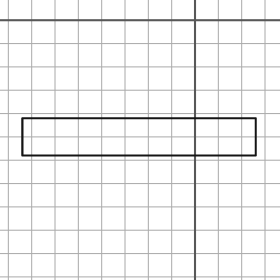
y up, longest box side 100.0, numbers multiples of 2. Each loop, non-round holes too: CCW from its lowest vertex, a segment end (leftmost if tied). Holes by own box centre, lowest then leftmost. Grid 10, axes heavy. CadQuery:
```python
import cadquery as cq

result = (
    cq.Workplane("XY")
    .moveTo(-74.0, -58.0)
    .lineTo(26.0, -58.0)
    .lineTo(26.0, -42.0)
    .lineTo(-74.0, -42.0)
    .close()
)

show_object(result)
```